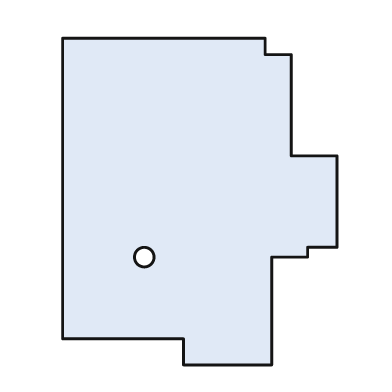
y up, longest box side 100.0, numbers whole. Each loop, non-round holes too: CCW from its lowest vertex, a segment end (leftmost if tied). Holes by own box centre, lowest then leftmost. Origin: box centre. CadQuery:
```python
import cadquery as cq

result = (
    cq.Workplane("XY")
    .moveTo(-5.0, -50.0)
    .lineTo(22.0, -50.0)
    .lineTo(22.0, -17.0)
    .lineTo(33.0, -17.0)
    .lineTo(33.0, -14.0)
    .lineTo(42.0, -14.0)
    .lineTo(42.0, 14.0)
    .lineTo(28.0, 14.0)
    .lineTo(28.0, 45.0)
    .lineTo(20.0, 45.0)
    .lineTo(20.0, 50.0)
    .lineTo(-42.0, 50.0)
    .lineTo(-42.0, -42.0)
    .lineTo(-5.0, -42.0)
    .close()
    .moveTo(-17.0, -17.0)
    .circle(3.0)
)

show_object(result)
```